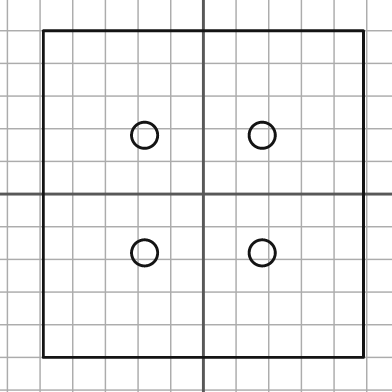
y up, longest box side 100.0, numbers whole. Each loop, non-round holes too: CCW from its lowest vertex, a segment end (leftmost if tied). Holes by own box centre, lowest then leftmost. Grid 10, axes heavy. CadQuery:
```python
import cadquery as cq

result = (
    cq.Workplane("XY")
    .moveTo(-49.0, -50.0)
    .lineTo(49.0, -50.0)
    .lineTo(49.0, 50.0)
    .lineTo(-49.0, 50.0)
    .close()
    .moveTo(-18.0, -18.0)
    .circle(4.0)
    .moveTo(18.0, -18.0)
    .circle(4.0)
    .moveTo(-18.0, 18.0)
    .circle(4.0)
    .moveTo(18.0, 18.0)
    .circle(4.0)
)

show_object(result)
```